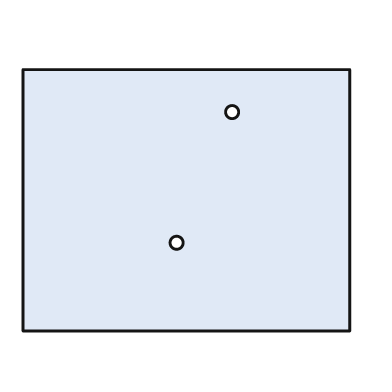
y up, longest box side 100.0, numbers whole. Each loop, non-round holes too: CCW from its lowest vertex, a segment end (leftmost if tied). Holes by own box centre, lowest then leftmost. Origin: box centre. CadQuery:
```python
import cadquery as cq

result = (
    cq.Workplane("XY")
    .moveTo(-50.0, -40.0)
    .lineTo(50.0, -40.0)
    .lineTo(50.0, 40.0)
    .lineTo(-50.0, 40.0)
    .close()
    .moveTo(-3.0, -13.0)
    .circle(2.0)
    .moveTo(14.0, 27.0)
    .circle(2.0)
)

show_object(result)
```